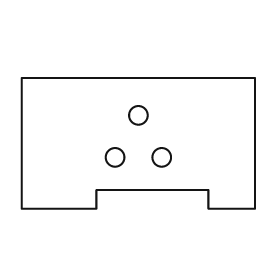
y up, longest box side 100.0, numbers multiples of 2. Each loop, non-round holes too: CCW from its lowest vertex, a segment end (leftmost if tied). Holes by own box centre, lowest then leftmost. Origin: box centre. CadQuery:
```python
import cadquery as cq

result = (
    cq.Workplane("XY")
    .moveTo(-50.0, -28.0)
    .lineTo(-18.0, -28.0)
    .lineTo(-18.0, -20.0)
    .lineTo(30.0, -20.0)
    .lineTo(30.0, -28.0)
    .lineTo(50.0, -28.0)
    .lineTo(50.0, 28.0)
    .lineTo(-50.0, 28.0)
    .close()
    .moveTo(-10.0, -6.0)
    .circle(4.0)
    .moveTo(10.0, -6.0)
    .circle(4.0)
    .moveTo(0.0, 12.0)
    .circle(4.0)
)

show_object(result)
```